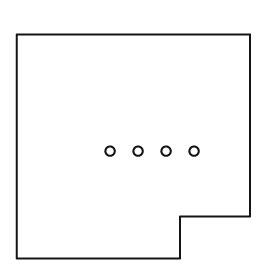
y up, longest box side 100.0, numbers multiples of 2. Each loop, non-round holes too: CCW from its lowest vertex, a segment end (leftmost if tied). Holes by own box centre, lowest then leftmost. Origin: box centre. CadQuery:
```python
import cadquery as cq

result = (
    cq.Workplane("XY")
    .moveTo(-50.0, -48.0)
    .lineTo(20.0, -48.0)
    .lineTo(20.0, -30.0)
    .lineTo(50.0, -30.0)
    .lineTo(50.0, 48.0)
    .lineTo(-50.0, 48.0)
    .close()
    .moveTo(-10.0, -2.0)
    .circle(2.0)
    .moveTo(2.0, -2.0)
    .circle(2.0)
    .moveTo(14.0, -2.0)
    .circle(2.0)
    .moveTo(26.0, -2.0)
    .circle(2.0)
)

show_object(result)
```